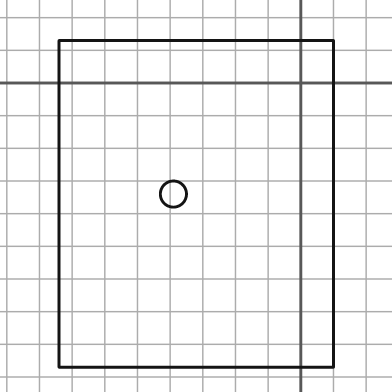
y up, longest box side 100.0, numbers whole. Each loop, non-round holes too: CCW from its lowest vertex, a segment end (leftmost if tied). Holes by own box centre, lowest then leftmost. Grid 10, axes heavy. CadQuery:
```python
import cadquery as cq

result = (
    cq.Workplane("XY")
    .moveTo(-74.0, -87.0)
    .lineTo(10.0, -87.0)
    .lineTo(10.0, 13.0)
    .lineTo(-74.0, 13.0)
    .close()
    .moveTo(-39.0, -34.0)
    .circle(4.0)
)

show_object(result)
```